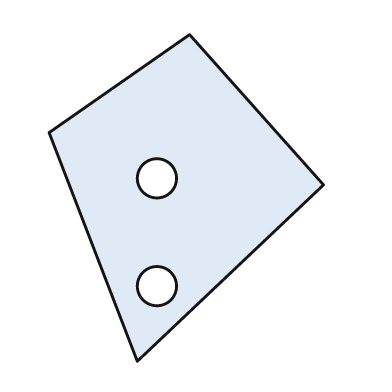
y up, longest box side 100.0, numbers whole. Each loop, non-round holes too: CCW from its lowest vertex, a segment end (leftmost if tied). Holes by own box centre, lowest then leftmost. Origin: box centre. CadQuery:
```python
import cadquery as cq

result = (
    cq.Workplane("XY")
    .moveTo(-15.0, -50.0)
    .lineTo(42.0, 4.0)
    .lineTo(1.0, 50.0)
    .lineTo(-42.0, 20.0)
    .close()
    .moveTo(-9.0, -27.0)
    .circle(6.0)
    .moveTo(-9.0, 6.0)
    .circle(6.0)
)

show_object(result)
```